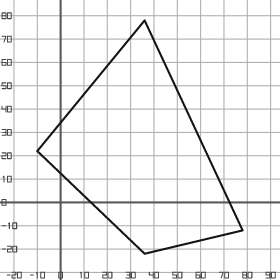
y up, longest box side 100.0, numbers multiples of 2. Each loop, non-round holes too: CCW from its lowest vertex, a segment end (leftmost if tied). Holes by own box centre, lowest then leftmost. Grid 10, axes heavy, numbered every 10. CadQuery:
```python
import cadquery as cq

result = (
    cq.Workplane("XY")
    .moveTo(36.0, -22.0)
    .lineTo(78.0, -12.0)
    .lineTo(36.0, 78.0)
    .lineTo(-10.0, 22.0)
    .close()
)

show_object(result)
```